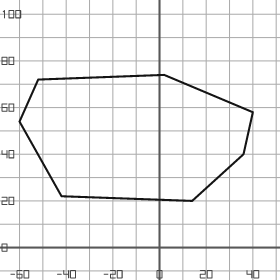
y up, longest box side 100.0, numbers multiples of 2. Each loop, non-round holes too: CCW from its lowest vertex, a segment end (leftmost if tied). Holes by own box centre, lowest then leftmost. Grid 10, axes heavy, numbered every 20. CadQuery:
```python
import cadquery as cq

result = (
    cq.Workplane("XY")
    .moveTo(14.0, 20.0)
    .lineTo(36.0, 40.0)
    .lineTo(40.0, 58.0)
    .lineTo(2.0, 74.0)
    .lineTo(-52.0, 72.0)
    .lineTo(-60.0, 54.0)
    .lineTo(-42.0, 22.0)
    .close()
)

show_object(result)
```